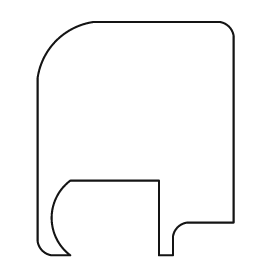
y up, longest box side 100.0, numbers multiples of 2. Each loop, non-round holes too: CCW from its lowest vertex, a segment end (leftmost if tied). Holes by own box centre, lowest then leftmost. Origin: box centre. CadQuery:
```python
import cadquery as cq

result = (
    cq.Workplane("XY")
    .moveTo(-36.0, -50.0)
    .lineTo(-28.0, -50.0)
    .threePointArc((-36.0, -34.0), (-28.0, -18.0))
    .lineTo(10.0, -18.0)
    .lineTo(10.0, -50.0)
    .lineTo(16.0, -50.0)
    .lineTo(16.0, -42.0)
    .threePointArc((18.0, -38.0), (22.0, -36.0))
    .lineTo(42.0, -36.0)
    .lineTo(42.0, 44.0)
    .threePointArc((40.0, 48.0), (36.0, 50.0))
    .lineTo(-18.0, 50.0)
    .threePointArc((-34.0, 42.0), (-42.0, 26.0))
    .lineTo(-42.0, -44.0)
    .threePointArc((-40.0, -48.0), (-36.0, -50.0))
    .close()
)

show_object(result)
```